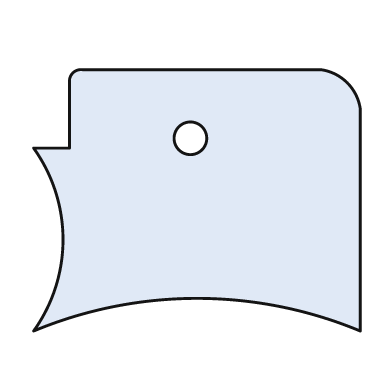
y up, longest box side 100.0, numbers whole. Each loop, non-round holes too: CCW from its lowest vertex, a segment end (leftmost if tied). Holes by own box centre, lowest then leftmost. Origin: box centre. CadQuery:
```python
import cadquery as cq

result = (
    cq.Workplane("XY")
    .moveTo(-50.0, -40.0)
    .threePointArc((0.0, -30.0), (50.0, -40.0))
    .lineTo(50.0, 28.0)
    .threePointArc((46.0, 36.0), (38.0, 40.0))
    .lineTo(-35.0, 40.0)
    .threePointArc((-38.0, 39.0), (-39.0, 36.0))
    .lineTo(-39.0, 16.0)
    .lineTo(-50.0, 16.0)
    .threePointArc((-41.0, -12.0), (-50.0, -40.0))
    .close()
    .moveTo(-2.0, 19.0)
    .circle(5.0)
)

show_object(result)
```